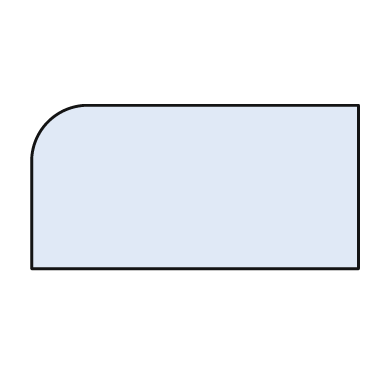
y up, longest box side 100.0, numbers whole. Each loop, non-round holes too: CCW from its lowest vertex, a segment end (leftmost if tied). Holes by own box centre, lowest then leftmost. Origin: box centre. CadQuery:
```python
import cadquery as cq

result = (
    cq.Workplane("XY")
    .moveTo(-50.0, -25.0)
    .lineTo(50.0, -25.0)
    .lineTo(50.0, 25.0)
    .lineTo(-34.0, 25.0)
    .threePointArc((-45.0, 20.0), (-50.0, 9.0))
    .close()
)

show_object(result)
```